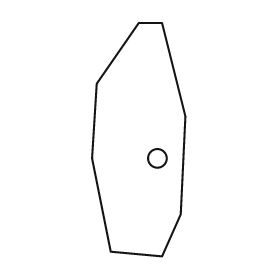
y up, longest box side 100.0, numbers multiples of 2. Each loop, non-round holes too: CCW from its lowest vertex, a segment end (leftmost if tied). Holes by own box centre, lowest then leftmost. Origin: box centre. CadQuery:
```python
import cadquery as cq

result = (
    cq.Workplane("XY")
    .moveTo(10.0, -50.0)
    .lineTo(18.0, -32.0)
    .lineTo(20.0, 10.0)
    .lineTo(10.0, 50.0)
    .lineTo(0.0, 50.0)
    .lineTo(-18.0, 24.0)
    .lineTo(-20.0, -8.0)
    .lineTo(-12.0, -48.0)
    .close()
    .moveTo(8.0, -8.0)
    .circle(4.0)
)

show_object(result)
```